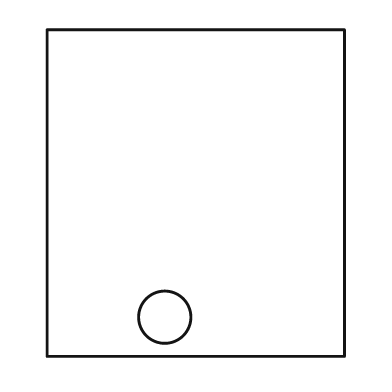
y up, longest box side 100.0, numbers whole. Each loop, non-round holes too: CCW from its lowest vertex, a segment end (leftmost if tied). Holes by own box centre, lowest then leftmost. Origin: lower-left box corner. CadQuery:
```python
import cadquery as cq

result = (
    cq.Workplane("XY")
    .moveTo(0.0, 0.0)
    .lineTo(91.0, 0.0)
    .lineTo(91.0, 100.0)
    .lineTo(0.0, 100.0)
    .close()
    .moveTo(36.0, 12.0)
    .circle(8.0)
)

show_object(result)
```